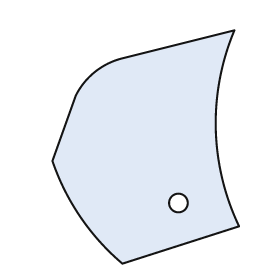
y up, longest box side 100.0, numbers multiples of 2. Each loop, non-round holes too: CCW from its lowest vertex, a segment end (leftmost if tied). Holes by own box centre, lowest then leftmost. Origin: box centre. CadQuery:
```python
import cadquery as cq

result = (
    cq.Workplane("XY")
    .moveTo(-10.0, -50.0)
    .lineTo(40.0, -34.0)
    .threePointArc((30.0, 8.0), (38.0, 50.0))
    .lineTo(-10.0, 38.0)
    .threePointArc((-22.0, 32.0), (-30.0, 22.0))
    .lineTo(-40.0, -6.0)
    .threePointArc((-28.0, -30.0), (-10.0, -50.0))
    .close()
    .moveTo(14.0, -24.0)
    .circle(4.0)
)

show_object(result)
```